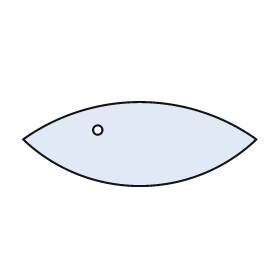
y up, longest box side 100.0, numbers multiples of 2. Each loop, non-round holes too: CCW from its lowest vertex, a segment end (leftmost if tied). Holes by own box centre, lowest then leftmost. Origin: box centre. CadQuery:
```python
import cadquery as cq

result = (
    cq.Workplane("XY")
    .moveTo(-50.0, 2.0)
    .threePointArc((0.0, -18.0), (50.0, 2.0))
    .threePointArc((0.0, 18.0), (-50.0, 2.0))
    .close()
    .moveTo(-18.0, 6.0)
    .circle(2.0)
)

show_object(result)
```